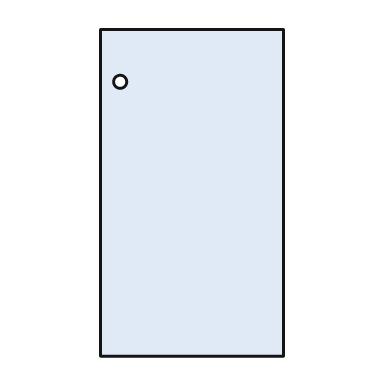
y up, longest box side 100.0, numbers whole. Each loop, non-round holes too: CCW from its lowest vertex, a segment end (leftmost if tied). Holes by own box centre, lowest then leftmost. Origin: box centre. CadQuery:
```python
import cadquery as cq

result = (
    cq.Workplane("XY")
    .moveTo(-28.0, -50.0)
    .lineTo(28.0, -50.0)
    .lineTo(28.0, 50.0)
    .lineTo(-28.0, 50.0)
    .close()
    .moveTo(-22.0, 34.0)
    .circle(2.0)
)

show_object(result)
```